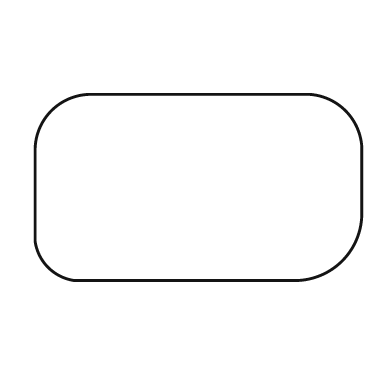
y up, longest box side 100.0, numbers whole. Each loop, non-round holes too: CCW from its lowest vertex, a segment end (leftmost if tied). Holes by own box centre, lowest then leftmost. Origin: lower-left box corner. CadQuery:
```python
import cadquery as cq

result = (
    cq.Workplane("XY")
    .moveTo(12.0, 0.0)
    .lineTo(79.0, 0.0)
    .threePointArc((94.0, 6.0), (100.0, 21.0))
    .lineTo(100.0, 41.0)
    .threePointArc((95.0, 52.0), (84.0, 57.0))
    .lineTo(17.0, 57.0)
    .threePointArc((5.0, 52.0), (0.0, 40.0))
    .lineTo(0.0, 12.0)
    .threePointArc((4.0, 4.0), (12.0, 0.0))
    .close()
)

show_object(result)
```